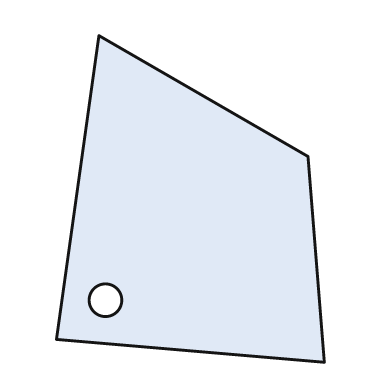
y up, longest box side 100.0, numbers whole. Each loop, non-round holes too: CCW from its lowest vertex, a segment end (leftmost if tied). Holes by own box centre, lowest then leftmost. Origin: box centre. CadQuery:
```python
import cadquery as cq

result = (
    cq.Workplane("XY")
    .moveTo(41.0, -50.0)
    .lineTo(36.0, 13.0)
    .lineTo(-28.0, 50.0)
    .lineTo(-41.0, -43.0)
    .close()
    .moveTo(-26.0, -31.0)
    .circle(5.0)
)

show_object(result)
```